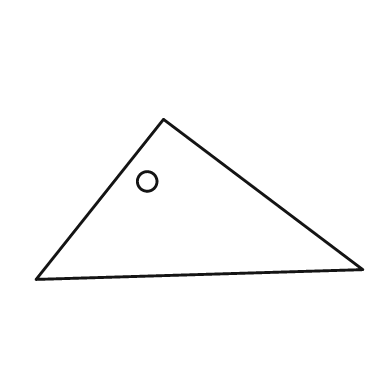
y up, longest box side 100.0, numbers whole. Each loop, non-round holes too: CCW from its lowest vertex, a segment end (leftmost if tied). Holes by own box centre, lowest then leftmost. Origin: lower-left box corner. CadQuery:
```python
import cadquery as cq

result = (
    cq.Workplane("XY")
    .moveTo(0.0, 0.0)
    .lineTo(100.0, 3.0)
    .lineTo(39.0, 49.0)
    .close()
    .moveTo(34.0, 30.0)
    .circle(3.0)
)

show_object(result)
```